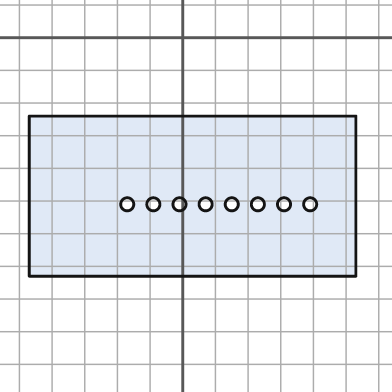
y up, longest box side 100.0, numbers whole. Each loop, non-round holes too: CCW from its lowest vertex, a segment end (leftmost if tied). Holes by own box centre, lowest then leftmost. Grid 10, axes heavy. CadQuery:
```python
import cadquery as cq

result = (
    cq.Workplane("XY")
    .moveTo(-47.0, -73.0)
    .lineTo(53.0, -73.0)
    .lineTo(53.0, -24.0)
    .lineTo(-47.0, -24.0)
    .close()
    .moveTo(-17.0, -51.0)
    .circle(2.0)
    .moveTo(-9.0, -51.0)
    .circle(2.0)
    .moveTo(-1.0, -51.0)
    .circle(2.0)
    .moveTo(7.0, -51.0)
    .circle(2.0)
    .moveTo(15.0, -51.0)
    .circle(2.0)
    .moveTo(23.0, -51.0)
    .circle(2.0)
    .moveTo(31.0, -51.0)
    .circle(2.0)
    .moveTo(39.0, -51.0)
    .circle(2.0)
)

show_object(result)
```